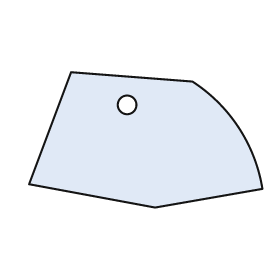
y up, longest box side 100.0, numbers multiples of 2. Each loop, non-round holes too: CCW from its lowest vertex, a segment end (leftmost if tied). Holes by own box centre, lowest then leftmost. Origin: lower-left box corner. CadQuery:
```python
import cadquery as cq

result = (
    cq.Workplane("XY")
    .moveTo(54.0, 0.0)
    .lineTo(100.0, 8.0)
    .threePointArc((90.0, 34.0), (70.0, 54.0))
    .lineTo(18.0, 58.0)
    .lineTo(0.0, 10.0)
    .close()
    .moveTo(42.0, 44.0)
    .circle(4.0)
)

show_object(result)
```